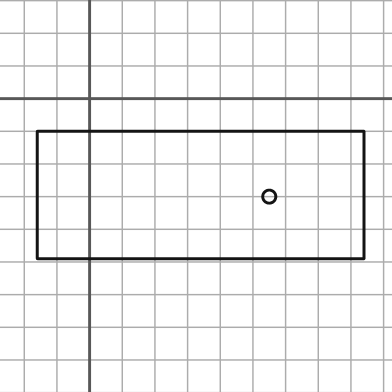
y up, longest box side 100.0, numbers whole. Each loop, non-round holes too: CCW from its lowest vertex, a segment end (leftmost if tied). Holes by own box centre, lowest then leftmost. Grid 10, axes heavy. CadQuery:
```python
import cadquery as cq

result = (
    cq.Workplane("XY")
    .moveTo(-16.0, -49.0)
    .lineTo(84.0, -49.0)
    .lineTo(84.0, -10.0)
    .lineTo(-16.0, -10.0)
    .close()
    .moveTo(55.0, -30.0)
    .circle(2.0)
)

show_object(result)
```